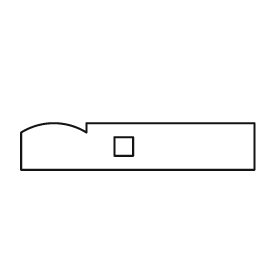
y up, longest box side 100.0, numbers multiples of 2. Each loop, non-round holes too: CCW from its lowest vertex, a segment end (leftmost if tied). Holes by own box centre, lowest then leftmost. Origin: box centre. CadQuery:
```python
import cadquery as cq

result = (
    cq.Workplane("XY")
    .moveTo(-50.0, -10.0)
    .lineTo(50.0, -10.0)
    .lineTo(50.0, 10.0)
    .lineTo(-22.0, 10.0)
    .lineTo(-22.0, 6.0)
    .threePointArc((-36.0, 10.0), (-50.0, 6.0))
    .close()
    .moveTo(-10.0, -4.0)
    .lineTo(-2.0, -4.0)
    .lineTo(-2.0, 4.0)
    .lineTo(-10.0, 4.0)
    .close()
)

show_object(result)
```